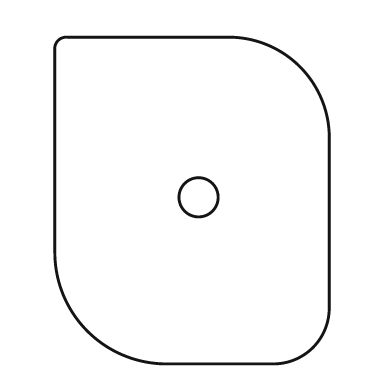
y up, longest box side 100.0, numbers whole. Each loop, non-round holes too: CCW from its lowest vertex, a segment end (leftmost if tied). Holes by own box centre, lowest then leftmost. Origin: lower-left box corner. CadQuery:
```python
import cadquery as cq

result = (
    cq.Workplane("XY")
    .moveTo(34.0, 0.0)
    .lineTo(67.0, 0.0)
    .threePointArc((79.0, 5.0), (84.0, 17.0))
    .lineTo(84.0, 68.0)
    .threePointArc((75.0, 91.0), (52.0, 100.0))
    .lineTo(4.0, 100.0)
    .threePointArc((1.0, 99.0), (0.0, 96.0))
    .lineTo(0.0, 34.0)
    .threePointArc((10.0, 10.0), (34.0, 0.0))
    .close()
    .moveTo(44.0, 51.0)
    .circle(6.0)
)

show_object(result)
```